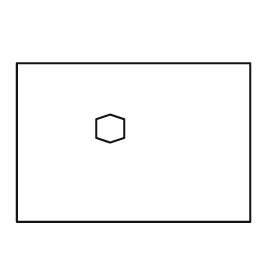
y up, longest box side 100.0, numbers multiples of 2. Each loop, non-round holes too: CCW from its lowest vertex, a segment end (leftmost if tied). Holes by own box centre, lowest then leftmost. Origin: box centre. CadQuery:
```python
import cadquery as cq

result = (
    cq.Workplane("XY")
    .moveTo(-50.0, -34.0)
    .lineTo(50.0, -34.0)
    .lineTo(50.0, 34.0)
    .lineTo(-50.0, 34.0)
    .close()
    .moveTo(-10.0, 0.0)
    .lineTo(-4.0, 2.0)
    .lineTo(-4.0, 10.0)
    .lineTo(-10.0, 12.0)
    .lineTo(-16.0, 10.0)
    .lineTo(-16.0, 2.0)
    .close()
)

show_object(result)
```